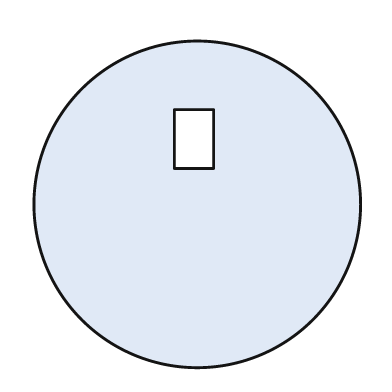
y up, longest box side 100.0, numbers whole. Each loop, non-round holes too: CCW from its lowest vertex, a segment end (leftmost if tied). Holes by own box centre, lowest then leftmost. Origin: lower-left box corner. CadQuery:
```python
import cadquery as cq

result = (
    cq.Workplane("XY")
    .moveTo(50.0, 50.0)
    .circle(50.0)
    .moveTo(43.0, 61.0)
    .lineTo(55.0, 61.0)
    .lineTo(55.0, 79.0)
    .lineTo(43.0, 79.0)
    .close()
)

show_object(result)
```